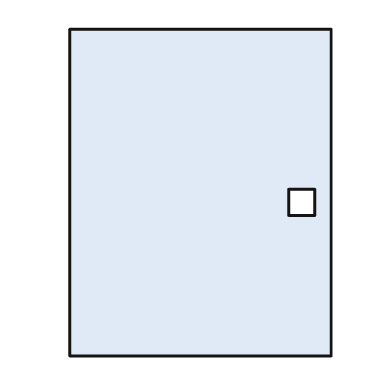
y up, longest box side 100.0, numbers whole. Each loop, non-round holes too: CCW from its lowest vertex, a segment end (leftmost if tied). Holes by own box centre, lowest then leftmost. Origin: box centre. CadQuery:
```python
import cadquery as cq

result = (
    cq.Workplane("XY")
    .moveTo(-40.0, -50.0)
    .lineTo(40.0, -50.0)
    .lineTo(40.0, 50.0)
    .lineTo(-40.0, 50.0)
    .close()
    .moveTo(27.0, -7.0)
    .lineTo(35.0, -7.0)
    .lineTo(35.0, 1.0)
    .lineTo(27.0, 1.0)
    .close()
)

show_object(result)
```